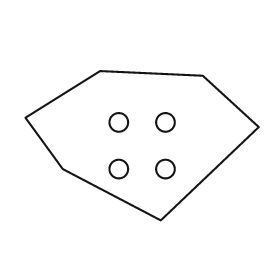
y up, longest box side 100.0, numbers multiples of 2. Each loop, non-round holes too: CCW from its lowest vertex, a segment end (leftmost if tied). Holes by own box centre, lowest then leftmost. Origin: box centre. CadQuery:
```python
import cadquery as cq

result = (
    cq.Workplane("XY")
    .moveTo(8.0, -32.0)
    .lineTo(50.0, 8.0)
    .lineTo(26.0, 30.0)
    .lineTo(-18.0, 32.0)
    .lineTo(-50.0, 12.0)
    .lineTo(-34.0, -10.0)
    .close()
    .moveTo(-10.0, -10.0)
    .circle(4.0)
    .moveTo(10.0, -10.0)
    .circle(4.0)
    .moveTo(-10.0, 10.0)
    .circle(4.0)
    .moveTo(10.0, 10.0)
    .circle(4.0)
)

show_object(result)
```